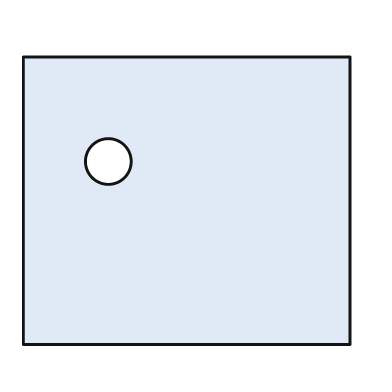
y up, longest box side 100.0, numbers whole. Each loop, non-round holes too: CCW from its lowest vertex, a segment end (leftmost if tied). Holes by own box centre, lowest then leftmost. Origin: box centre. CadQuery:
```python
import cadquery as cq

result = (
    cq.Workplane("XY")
    .moveTo(-50.0, -44.0)
    .lineTo(50.0, -44.0)
    .lineTo(50.0, 44.0)
    .lineTo(-50.0, 44.0)
    .close()
    .moveTo(-24.0, 12.0)
    .circle(7.0)
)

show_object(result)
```